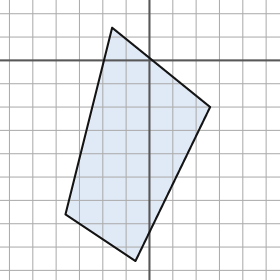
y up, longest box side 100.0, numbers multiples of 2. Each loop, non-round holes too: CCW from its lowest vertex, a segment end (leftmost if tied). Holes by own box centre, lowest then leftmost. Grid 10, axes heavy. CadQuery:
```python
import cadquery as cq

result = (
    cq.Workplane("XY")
    .moveTo(-6.0, -86.0)
    .lineTo(26.0, -20.0)
    .lineTo(-16.0, 14.0)
    .lineTo(-36.0, -66.0)
    .close()
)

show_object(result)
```